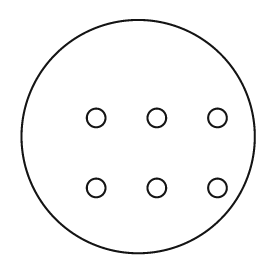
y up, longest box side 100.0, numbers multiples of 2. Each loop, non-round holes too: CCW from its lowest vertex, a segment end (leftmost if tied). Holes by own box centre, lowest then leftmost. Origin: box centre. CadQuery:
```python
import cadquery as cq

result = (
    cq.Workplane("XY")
    .moveTo(0.0, 0.0)
    .circle(50.0)
    .moveTo(-18.0, -22.0)
    .circle(4.0)
    .moveTo(8.0, -22.0)
    .circle(4.0)
    .moveTo(34.0, -22.0)
    .circle(4.0)
    .moveTo(-18.0, 8.0)
    .circle(4.0)
    .moveTo(8.0, 8.0)
    .circle(4.0)
    .moveTo(34.0, 8.0)
    .circle(4.0)
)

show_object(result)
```